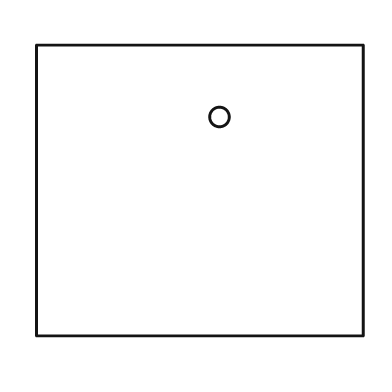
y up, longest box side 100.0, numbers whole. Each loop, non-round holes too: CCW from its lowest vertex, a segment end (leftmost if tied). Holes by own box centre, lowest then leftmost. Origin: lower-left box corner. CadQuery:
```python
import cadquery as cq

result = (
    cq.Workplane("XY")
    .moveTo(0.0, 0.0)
    .lineTo(100.0, 0.0)
    .lineTo(100.0, 89.0)
    .lineTo(0.0, 89.0)
    .close()
    .moveTo(56.0, 67.0)
    .circle(3.0)
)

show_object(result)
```